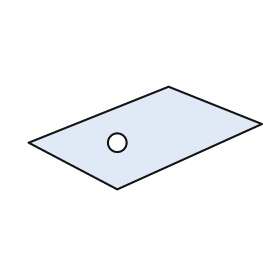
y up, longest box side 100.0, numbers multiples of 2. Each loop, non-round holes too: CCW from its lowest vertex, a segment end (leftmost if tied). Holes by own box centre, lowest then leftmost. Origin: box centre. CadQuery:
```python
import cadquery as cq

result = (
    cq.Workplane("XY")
    .moveTo(-12.0, -22.0)
    .lineTo(50.0, 6.0)
    .lineTo(10.0, 22.0)
    .lineTo(-50.0, -2.0)
    .close()
    .moveTo(-12.0, -2.0)
    .circle(4.0)
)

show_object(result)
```